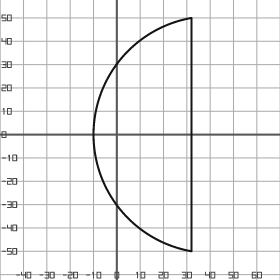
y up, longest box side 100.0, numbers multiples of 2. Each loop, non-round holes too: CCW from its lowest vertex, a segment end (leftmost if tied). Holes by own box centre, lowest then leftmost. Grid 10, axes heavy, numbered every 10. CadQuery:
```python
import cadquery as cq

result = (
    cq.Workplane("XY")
    .moveTo(32.0, -50.0)
    .lineTo(32.0, 50.0)
    .threePointArc((-10.0, 0.0), (32.0, -50.0))
    .close()
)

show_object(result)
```